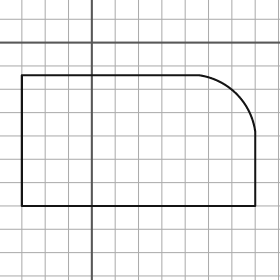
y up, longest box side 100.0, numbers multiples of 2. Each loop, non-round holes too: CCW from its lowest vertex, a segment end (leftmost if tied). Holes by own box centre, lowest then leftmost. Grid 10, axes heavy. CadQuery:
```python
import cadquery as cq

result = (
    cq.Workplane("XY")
    .moveTo(-30.0, -70.0)
    .lineTo(70.0, -70.0)
    .lineTo(70.0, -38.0)
    .threePointArc((62.0, -22.0), (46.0, -14.0))
    .lineTo(-30.0, -14.0)
    .close()
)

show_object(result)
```